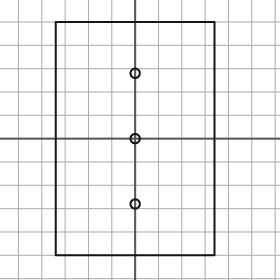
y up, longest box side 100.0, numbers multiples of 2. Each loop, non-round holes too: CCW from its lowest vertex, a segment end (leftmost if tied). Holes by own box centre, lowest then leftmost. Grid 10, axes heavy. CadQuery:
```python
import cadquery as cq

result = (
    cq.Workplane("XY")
    .moveTo(-34.0, -50.0)
    .lineTo(34.0, -50.0)
    .lineTo(34.0, 50.0)
    .lineTo(-34.0, 50.0)
    .close()
    .moveTo(0.0, -28.0)
    .circle(2.0)
    .moveTo(0.0, 0.0)
    .circle(2.0)
    .moveTo(0.0, 28.0)
    .circle(2.0)
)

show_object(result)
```